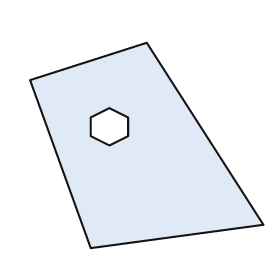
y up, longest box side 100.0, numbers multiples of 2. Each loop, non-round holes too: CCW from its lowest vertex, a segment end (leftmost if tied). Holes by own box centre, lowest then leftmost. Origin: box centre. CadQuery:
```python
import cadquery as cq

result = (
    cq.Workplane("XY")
    .moveTo(-24.0, -44.0)
    .lineTo(50.0, -34.0)
    .lineTo(0.0, 44.0)
    .lineTo(-50.0, 28.0)
    .close()
    .moveTo(-16.0, 0.0)
    .lineTo(-8.0, 4.0)
    .lineTo(-8.0, 12.0)
    .lineTo(-16.0, 16.0)
    .lineTo(-24.0, 12.0)
    .lineTo(-24.0, 4.0)
    .close()
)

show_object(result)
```